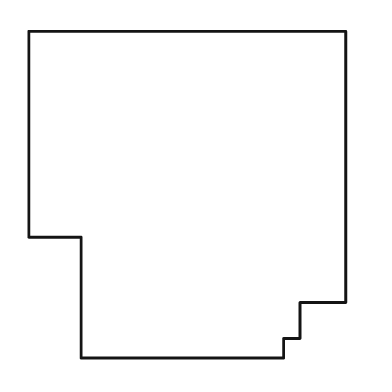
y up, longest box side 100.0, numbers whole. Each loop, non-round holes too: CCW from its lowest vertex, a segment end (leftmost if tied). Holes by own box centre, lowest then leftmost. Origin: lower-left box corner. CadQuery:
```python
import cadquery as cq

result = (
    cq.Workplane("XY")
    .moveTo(16.0, 0.0)
    .lineTo(78.0, 0.0)
    .lineTo(78.0, 6.0)
    .lineTo(83.0, 6.0)
    .lineTo(83.0, 17.0)
    .lineTo(97.0, 17.0)
    .lineTo(97.0, 100.0)
    .lineTo(0.0, 100.0)
    .lineTo(0.0, 37.0)
    .lineTo(16.0, 37.0)
    .close()
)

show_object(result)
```